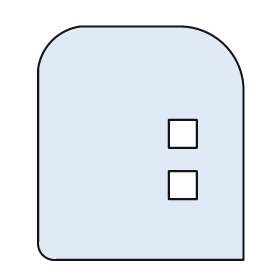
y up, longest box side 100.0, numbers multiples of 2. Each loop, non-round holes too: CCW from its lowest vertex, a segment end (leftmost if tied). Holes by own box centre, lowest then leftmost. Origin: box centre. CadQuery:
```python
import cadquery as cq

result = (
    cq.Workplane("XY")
    .moveTo(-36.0, -50.0)
    .lineTo(44.0, -50.0)
    .lineTo(44.0, 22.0)
    .threePointArc((36.0, 42.0), (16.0, 50.0))
    .lineTo(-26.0, 50.0)
    .threePointArc((-38.0, 44.0), (-44.0, 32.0))
    .lineTo(-44.0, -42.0)
    .threePointArc((-42.0, -48.0), (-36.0, -50.0))
    .close()
    .moveTo(12.0, -24.0)
    .lineTo(24.0, -24.0)
    .lineTo(24.0, -12.0)
    .lineTo(12.0, -12.0)
    .close()
    .moveTo(12.0, -2.0)
    .lineTo(24.0, -2.0)
    .lineTo(24.0, 10.0)
    .lineTo(12.0, 10.0)
    .close()
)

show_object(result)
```